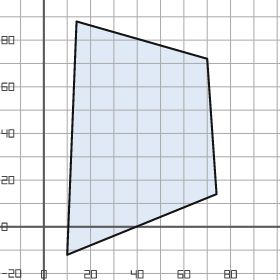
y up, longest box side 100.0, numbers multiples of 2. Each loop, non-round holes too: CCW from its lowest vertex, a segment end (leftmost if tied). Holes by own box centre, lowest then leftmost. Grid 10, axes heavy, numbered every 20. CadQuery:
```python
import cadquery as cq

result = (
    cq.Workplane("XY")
    .moveTo(10.0, -12.0)
    .lineTo(74.0, 14.0)
    .lineTo(70.0, 72.0)
    .lineTo(14.0, 88.0)
    .close()
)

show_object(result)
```